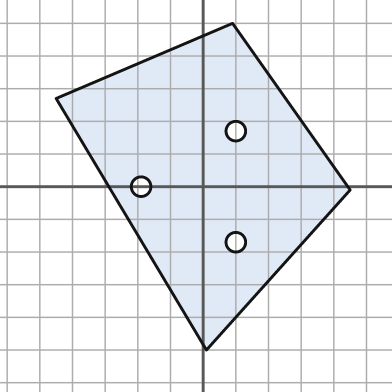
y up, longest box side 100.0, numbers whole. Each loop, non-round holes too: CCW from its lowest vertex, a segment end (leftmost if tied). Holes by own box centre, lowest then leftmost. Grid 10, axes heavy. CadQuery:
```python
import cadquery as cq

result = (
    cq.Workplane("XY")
    .moveTo(1.0, -50.0)
    .lineTo(45.0, -1.0)
    .lineTo(9.0, 50.0)
    .lineTo(-45.0, 27.0)
    .close()
    .moveTo(10.0, -17.0)
    .circle(3.0)
    .moveTo(-19.0, 0.0)
    .circle(3.0)
    .moveTo(10.0, 17.0)
    .circle(3.0)
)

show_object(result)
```